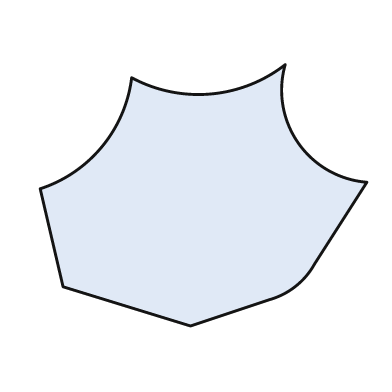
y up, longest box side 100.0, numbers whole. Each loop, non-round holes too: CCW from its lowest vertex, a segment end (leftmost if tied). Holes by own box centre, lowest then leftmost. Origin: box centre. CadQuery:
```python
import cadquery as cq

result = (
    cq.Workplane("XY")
    .moveTo(-4.0, -40.0)
    .lineTo(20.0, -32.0)
    .threePointArc((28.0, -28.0), (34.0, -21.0))
    .lineTo(50.0, 4.0)
    .threePointArc((29.0, 16.0), (25.0, 40.0))
    .threePointArc((2.0, 31.0), (-22.0, 36.0))
    .threePointArc((-31.0, 15.0), (-50.0, 2.0))
    .lineTo(-43.0, -28.0)
    .close()
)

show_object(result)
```